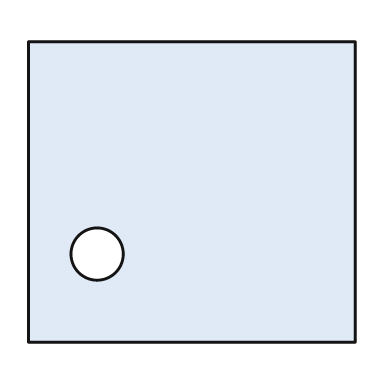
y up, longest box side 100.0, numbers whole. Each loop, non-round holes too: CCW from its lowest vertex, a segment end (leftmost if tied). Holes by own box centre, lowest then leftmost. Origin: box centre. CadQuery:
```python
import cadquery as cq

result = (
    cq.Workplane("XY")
    .moveTo(-50.0, -46.0)
    .lineTo(50.0, -46.0)
    .lineTo(50.0, 46.0)
    .lineTo(-50.0, 46.0)
    .close()
    .moveTo(-29.0, -19.0)
    .circle(8.0)
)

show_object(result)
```